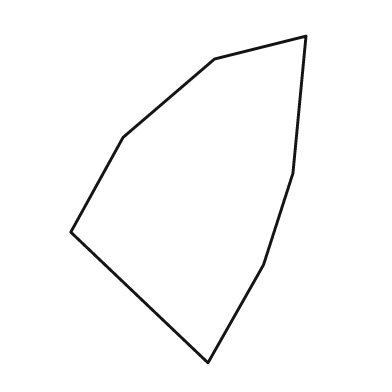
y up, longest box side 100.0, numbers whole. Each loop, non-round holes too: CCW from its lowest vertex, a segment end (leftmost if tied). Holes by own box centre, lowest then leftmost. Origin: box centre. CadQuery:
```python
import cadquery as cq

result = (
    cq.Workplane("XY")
    .moveTo(6.0, -50.0)
    .lineTo(23.0, -20.0)
    .lineTo(32.0, 8.0)
    .lineTo(36.0, 50.0)
    .lineTo(8.0, 43.0)
    .lineTo(-20.0, 19.0)
    .lineTo(-36.0, -10.0)
    .close()
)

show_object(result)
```